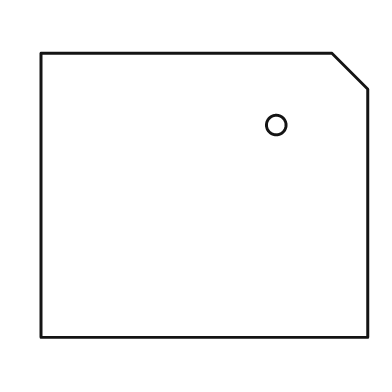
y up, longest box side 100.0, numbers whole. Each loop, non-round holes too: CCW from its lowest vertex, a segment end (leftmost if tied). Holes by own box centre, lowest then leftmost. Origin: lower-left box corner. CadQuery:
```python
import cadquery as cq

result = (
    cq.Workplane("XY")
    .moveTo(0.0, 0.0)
    .lineTo(100.0, 0.0)
    .lineTo(100.0, 76.0)
    .lineTo(89.0, 87.0)
    .lineTo(0.0, 87.0)
    .close()
    .moveTo(72.0, 65.0)
    .circle(3.0)
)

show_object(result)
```